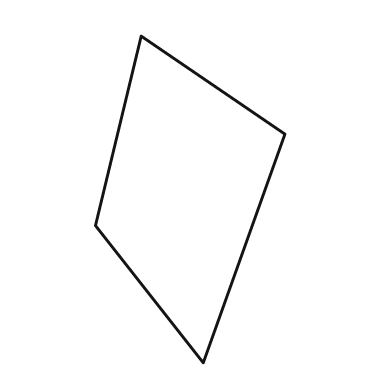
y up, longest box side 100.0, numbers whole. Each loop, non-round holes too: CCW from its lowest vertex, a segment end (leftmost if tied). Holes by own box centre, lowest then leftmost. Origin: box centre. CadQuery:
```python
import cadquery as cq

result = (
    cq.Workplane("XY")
    .moveTo(4.0, -50.0)
    .lineTo(29.0, 20.0)
    .lineTo(-15.0, 50.0)
    .lineTo(-29.0, -8.0)
    .close()
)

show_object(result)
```